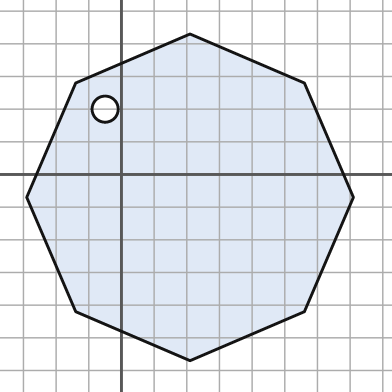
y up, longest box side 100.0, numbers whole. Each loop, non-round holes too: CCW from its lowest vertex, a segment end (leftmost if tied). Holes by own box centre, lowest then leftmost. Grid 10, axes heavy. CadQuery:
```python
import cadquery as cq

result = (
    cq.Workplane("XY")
    .moveTo(21.0, -57.0)
    .lineTo(56.0, -42.0)
    .lineTo(71.0, -7.0)
    .lineTo(56.0, 28.0)
    .lineTo(21.0, 43.0)
    .lineTo(-14.0, 28.0)
    .lineTo(-29.0, -7.0)
    .lineTo(-14.0, -42.0)
    .close()
    .moveTo(-5.0, 20.0)
    .circle(4.0)
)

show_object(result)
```